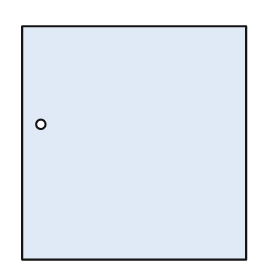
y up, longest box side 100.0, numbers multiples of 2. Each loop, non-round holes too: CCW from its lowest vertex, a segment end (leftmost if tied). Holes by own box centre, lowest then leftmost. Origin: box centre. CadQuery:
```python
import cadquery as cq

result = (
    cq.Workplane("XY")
    .moveTo(-48.0, -50.0)
    .lineTo(48.0, -50.0)
    .lineTo(48.0, 50.0)
    .lineTo(-48.0, 50.0)
    .close()
    .moveTo(-40.0, 8.0)
    .circle(2.0)
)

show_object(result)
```